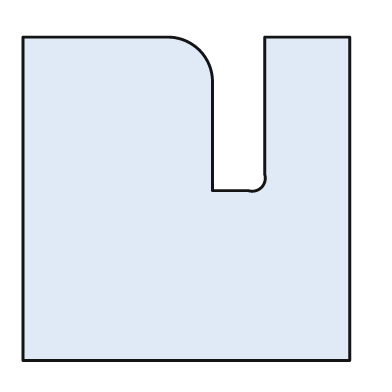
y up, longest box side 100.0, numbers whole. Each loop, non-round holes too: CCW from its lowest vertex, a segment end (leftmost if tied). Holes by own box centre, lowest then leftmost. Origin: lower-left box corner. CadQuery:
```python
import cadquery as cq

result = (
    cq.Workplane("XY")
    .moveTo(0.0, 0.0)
    .lineTo(100.0, 0.0)
    .lineTo(100.0, 99.0)
    .lineTo(74.0, 99.0)
    .lineTo(74.0, 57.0)
    .threePointArc((73.0, 53.0), (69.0, 52.0))
    .lineTo(58.0, 52.0)
    .lineTo(58.0, 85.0)
    .threePointArc((54.0, 95.0), (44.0, 99.0))
    .lineTo(0.0, 99.0)
    .close()
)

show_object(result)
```